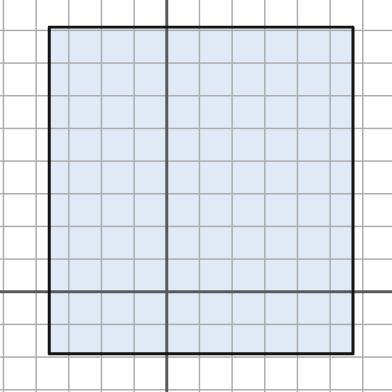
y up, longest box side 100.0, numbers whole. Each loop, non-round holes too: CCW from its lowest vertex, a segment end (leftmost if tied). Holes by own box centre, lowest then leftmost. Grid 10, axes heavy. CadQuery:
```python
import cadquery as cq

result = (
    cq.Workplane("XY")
    .moveTo(-36.0, -19.0)
    .lineTo(57.0, -19.0)
    .lineTo(57.0, 81.0)
    .lineTo(-36.0, 81.0)
    .close()
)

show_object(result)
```